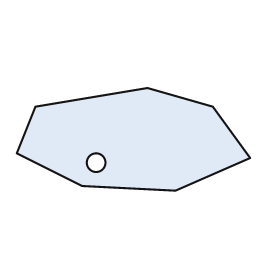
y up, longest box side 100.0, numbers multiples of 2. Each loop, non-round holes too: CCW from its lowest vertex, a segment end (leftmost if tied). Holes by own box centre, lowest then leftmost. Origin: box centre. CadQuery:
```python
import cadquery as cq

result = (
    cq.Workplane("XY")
    .moveTo(18.0, -22.0)
    .lineTo(50.0, -8.0)
    .lineTo(34.0, 14.0)
    .lineTo(6.0, 22.0)
    .lineTo(-42.0, 14.0)
    .lineTo(-50.0, -6.0)
    .lineTo(-22.0, -20.0)
    .close()
    .moveTo(-16.0, -10.0)
    .circle(4.0)
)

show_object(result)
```